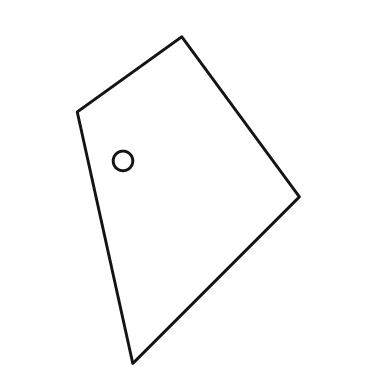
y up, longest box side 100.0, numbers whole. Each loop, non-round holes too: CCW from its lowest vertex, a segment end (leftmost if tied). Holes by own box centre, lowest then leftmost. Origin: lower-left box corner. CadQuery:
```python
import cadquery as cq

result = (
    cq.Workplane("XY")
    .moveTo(17.0, 0.0)
    .lineTo(68.0, 51.0)
    .lineTo(32.0, 100.0)
    .lineTo(0.0, 77.0)
    .close()
    .moveTo(14.0, 62.0)
    .circle(3.0)
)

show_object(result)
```